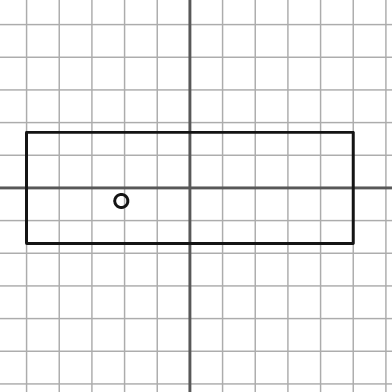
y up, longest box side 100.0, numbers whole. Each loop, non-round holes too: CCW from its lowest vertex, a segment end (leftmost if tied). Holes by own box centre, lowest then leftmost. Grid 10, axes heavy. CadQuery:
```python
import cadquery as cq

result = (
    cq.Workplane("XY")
    .moveTo(-50.0, -17.0)
    .lineTo(50.0, -17.0)
    .lineTo(50.0, 17.0)
    .lineTo(-50.0, 17.0)
    .close()
    .moveTo(-21.0, -4.0)
    .circle(2.0)
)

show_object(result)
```